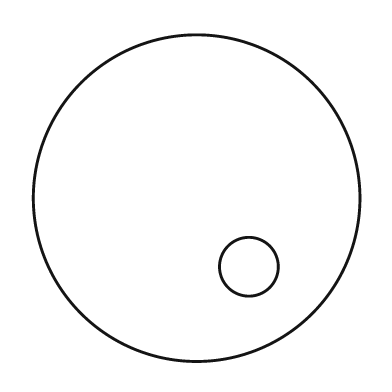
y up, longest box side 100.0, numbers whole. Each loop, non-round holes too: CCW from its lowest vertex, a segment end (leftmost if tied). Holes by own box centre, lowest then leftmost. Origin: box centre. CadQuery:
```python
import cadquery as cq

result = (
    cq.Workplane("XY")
    .moveTo(0.0, 0.0)
    .circle(50.0)
    .moveTo(16.0, -21.0)
    .circle(9.0)
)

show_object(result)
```